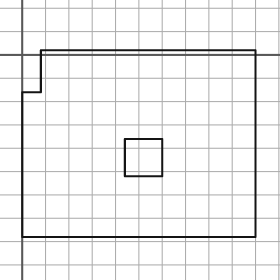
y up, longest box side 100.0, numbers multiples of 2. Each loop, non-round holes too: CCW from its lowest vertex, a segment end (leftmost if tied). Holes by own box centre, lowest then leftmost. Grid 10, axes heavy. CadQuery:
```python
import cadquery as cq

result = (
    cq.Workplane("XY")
    .moveTo(0.0, -78.0)
    .lineTo(100.0, -78.0)
    .lineTo(100.0, 2.0)
    .lineTo(8.0, 2.0)
    .lineTo(8.0, -16.0)
    .lineTo(0.0, -16.0)
    .close()
    .moveTo(44.0, -52.0)
    .lineTo(60.0, -52.0)
    .lineTo(60.0, -36.0)
    .lineTo(44.0, -36.0)
    .close()
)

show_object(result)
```